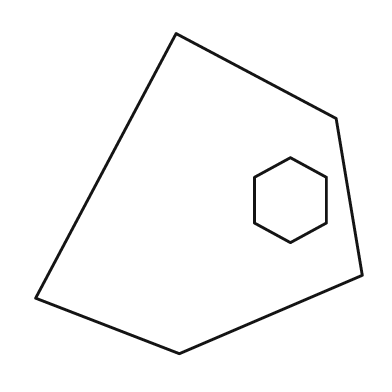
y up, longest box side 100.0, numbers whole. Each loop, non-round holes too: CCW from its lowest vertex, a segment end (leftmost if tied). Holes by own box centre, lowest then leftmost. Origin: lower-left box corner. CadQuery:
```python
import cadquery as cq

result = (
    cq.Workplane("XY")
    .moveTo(44.0, 0.0)
    .lineTo(100.0, 24.0)
    .lineTo(92.0, 72.0)
    .lineTo(43.0, 98.0)
    .lineTo(0.0, 17.0)
    .close()
    .moveTo(78.0, 34.0)
    .lineTo(89.0, 40.0)
    .lineTo(89.0, 54.0)
    .lineTo(78.0, 60.0)
    .lineTo(67.0, 54.0)
    .lineTo(67.0, 40.0)
    .close()
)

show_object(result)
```